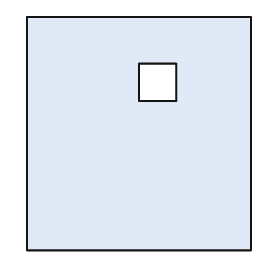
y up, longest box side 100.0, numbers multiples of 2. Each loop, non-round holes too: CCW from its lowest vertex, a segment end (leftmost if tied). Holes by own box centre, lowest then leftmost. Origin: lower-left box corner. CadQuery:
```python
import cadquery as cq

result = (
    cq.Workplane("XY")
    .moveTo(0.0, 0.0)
    .lineTo(96.0, 0.0)
    .lineTo(96.0, 100.0)
    .lineTo(0.0, 100.0)
    .close()
    .moveTo(48.0, 64.0)
    .lineTo(64.0, 64.0)
    .lineTo(64.0, 80.0)
    .lineTo(48.0, 80.0)
    .close()
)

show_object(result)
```